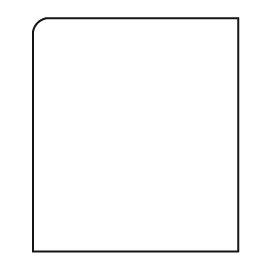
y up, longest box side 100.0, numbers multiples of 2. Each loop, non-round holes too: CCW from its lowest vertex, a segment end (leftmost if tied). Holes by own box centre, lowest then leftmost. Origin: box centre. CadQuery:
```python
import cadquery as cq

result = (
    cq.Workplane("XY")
    .moveTo(-44.0, -50.0)
    .lineTo(44.0, -50.0)
    .lineTo(44.0, 50.0)
    .lineTo(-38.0, 50.0)
    .threePointArc((-42.0, 48.0), (-44.0, 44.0))
    .close()
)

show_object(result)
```